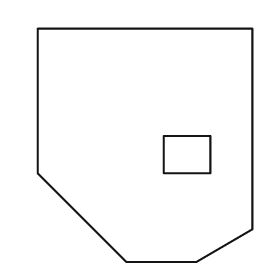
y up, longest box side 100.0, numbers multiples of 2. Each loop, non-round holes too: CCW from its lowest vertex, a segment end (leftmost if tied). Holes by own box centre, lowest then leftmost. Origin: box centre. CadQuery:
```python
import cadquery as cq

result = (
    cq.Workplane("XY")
    .moveTo(-8.0, -50.0)
    .lineTo(22.0, -50.0)
    .lineTo(46.0, -36.0)
    .lineTo(46.0, 50.0)
    .lineTo(-46.0, 50.0)
    .lineTo(-46.0, -12.0)
    .close()
    .moveTo(8.0, -12.0)
    .lineTo(28.0, -12.0)
    .lineTo(28.0, 4.0)
    .lineTo(8.0, 4.0)
    .close()
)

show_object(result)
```